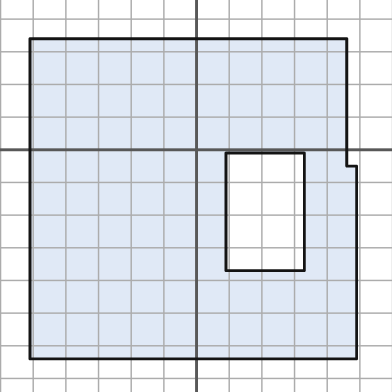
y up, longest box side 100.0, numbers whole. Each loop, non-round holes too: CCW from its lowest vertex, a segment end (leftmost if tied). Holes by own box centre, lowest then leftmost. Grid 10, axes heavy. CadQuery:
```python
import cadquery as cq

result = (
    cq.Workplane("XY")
    .moveTo(-51.0, -64.0)
    .lineTo(49.0, -64.0)
    .lineTo(49.0, -5.0)
    .lineTo(46.0, -5.0)
    .lineTo(46.0, 34.0)
    .lineTo(-51.0, 34.0)
    .close()
    .moveTo(9.0, -37.0)
    .lineTo(33.0, -37.0)
    .lineTo(33.0, -1.0)
    .lineTo(9.0, -1.0)
    .close()
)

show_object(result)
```